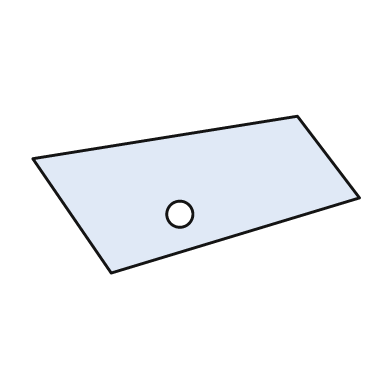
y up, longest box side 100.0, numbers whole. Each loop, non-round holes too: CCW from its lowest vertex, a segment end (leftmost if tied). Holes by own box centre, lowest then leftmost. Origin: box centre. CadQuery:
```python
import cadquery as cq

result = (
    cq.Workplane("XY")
    .moveTo(-26.0, -24.0)
    .lineTo(50.0, -1.0)
    .lineTo(31.0, 24.0)
    .lineTo(-50.0, 11.0)
    .close()
    .moveTo(-5.0, -6.0)
    .circle(4.0)
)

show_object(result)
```